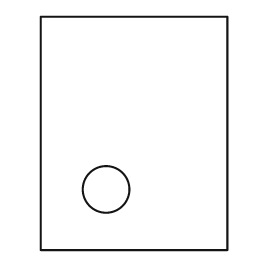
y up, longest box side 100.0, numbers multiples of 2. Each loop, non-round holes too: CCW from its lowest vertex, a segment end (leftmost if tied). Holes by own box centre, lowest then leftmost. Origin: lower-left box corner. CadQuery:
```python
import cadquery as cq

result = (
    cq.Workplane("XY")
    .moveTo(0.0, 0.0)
    .lineTo(80.0, 0.0)
    .lineTo(80.0, 100.0)
    .lineTo(0.0, 100.0)
    .close()
    .moveTo(28.0, 26.0)
    .circle(10.0)
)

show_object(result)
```